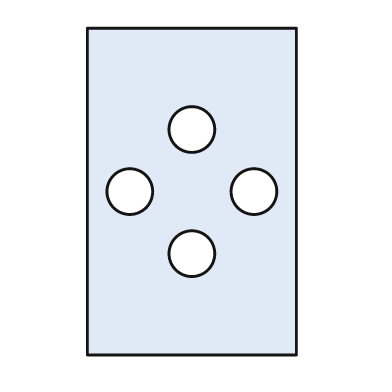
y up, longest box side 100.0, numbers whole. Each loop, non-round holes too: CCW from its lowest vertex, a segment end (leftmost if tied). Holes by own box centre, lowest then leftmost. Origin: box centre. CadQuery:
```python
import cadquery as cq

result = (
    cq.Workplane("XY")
    .moveTo(-32.0, -50.0)
    .lineTo(32.0, -50.0)
    .lineTo(32.0, 50.0)
    .lineTo(-32.0, 50.0)
    .close()
    .moveTo(0.0, -19.0)
    .circle(7.0)
    .moveTo(-19.0, 0.0)
    .circle(7.0)
    .moveTo(19.0, 0.0)
    .circle(7.0)
    .moveTo(0.0, 19.0)
    .circle(7.0)
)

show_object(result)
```